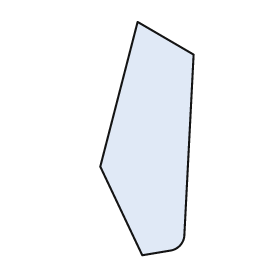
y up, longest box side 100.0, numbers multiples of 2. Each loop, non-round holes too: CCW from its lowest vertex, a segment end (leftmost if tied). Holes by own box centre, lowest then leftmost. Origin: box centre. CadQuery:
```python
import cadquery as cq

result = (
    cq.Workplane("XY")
    .moveTo(-2.0, -50.0)
    .lineTo(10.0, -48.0)
    .threePointArc((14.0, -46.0), (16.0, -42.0))
    .lineTo(20.0, 36.0)
    .lineTo(-4.0, 50.0)
    .lineTo(-20.0, -12.0)
    .close()
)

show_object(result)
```